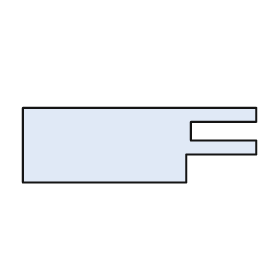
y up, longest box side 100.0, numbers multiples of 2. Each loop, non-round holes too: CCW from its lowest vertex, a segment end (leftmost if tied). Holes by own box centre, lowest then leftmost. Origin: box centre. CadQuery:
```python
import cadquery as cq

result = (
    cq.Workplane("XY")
    .moveTo(-50.0, -16.0)
    .lineTo(20.0, -16.0)
    .lineTo(20.0, -4.0)
    .lineTo(50.0, -4.0)
    .lineTo(50.0, 2.0)
    .lineTo(22.0, 2.0)
    .lineTo(22.0, 10.0)
    .lineTo(50.0, 10.0)
    .lineTo(50.0, 16.0)
    .lineTo(-50.0, 16.0)
    .close()
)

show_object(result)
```